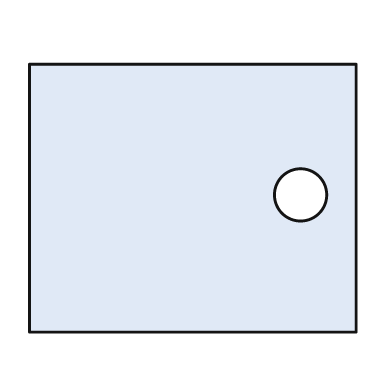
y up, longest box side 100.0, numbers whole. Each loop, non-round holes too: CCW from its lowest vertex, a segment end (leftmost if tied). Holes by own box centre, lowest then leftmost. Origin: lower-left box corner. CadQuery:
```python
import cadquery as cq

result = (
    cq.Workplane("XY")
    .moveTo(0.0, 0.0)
    .lineTo(100.0, 0.0)
    .lineTo(100.0, 82.0)
    .lineTo(0.0, 82.0)
    .close()
    .moveTo(83.0, 42.0)
    .circle(8.0)
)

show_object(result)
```